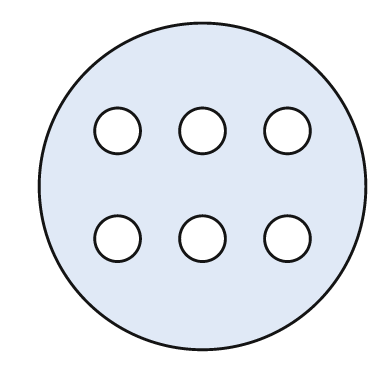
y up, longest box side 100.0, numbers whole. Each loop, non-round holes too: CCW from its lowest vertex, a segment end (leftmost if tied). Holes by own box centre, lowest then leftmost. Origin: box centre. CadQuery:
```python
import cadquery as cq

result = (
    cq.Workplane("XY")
    .moveTo(0.0, 0.0)
    .circle(50.0)
    .moveTo(-26.0, -16.0)
    .circle(7.0)
    .moveTo(0.0, -16.0)
    .circle(7.0)
    .moveTo(26.0, -16.0)
    .circle(7.0)
    .moveTo(-26.0, 17.0)
    .circle(7.0)
    .moveTo(0.0, 17.0)
    .circle(7.0)
    .moveTo(26.0, 17.0)
    .circle(7.0)
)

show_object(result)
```